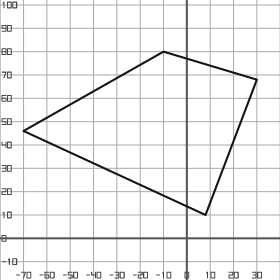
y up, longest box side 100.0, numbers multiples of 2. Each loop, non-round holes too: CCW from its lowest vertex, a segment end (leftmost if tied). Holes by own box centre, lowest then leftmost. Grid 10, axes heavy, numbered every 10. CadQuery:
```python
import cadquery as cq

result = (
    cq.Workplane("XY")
    .moveTo(8.0, 10.0)
    .lineTo(30.0, 68.0)
    .lineTo(-10.0, 80.0)
    .lineTo(-70.0, 46.0)
    .close()
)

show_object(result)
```